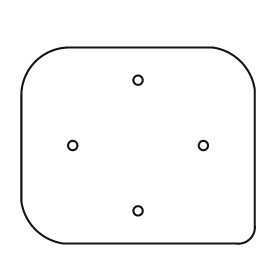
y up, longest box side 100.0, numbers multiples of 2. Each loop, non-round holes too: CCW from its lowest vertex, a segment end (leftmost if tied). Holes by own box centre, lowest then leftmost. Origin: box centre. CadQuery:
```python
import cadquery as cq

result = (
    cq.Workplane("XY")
    .moveTo(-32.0, -42.0)
    .lineTo(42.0, -42.0)
    .threePointArc((48.0, -40.0), (50.0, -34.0))
    .lineTo(50.0, 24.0)
    .threePointArc((44.0, 36.0), (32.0, 42.0))
    .lineTo(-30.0, 42.0)
    .threePointArc((-44.0, 36.0), (-50.0, 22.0))
    .lineTo(-50.0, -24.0)
    .threePointArc((-44.0, -36.0), (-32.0, -42.0))
    .close()
    .moveTo(0.0, -28.0)
    .circle(2.0)
    .moveTo(-28.0, 0.0)
    .circle(2.0)
    .moveTo(28.0, 0.0)
    .circle(2.0)
    .moveTo(0.0, 28.0)
    .circle(2.0)
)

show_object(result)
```